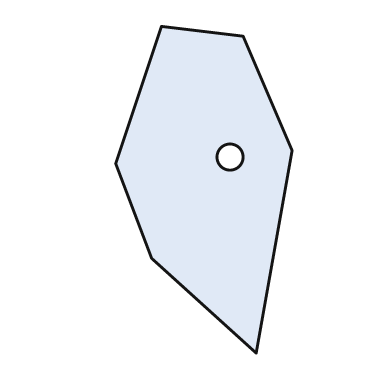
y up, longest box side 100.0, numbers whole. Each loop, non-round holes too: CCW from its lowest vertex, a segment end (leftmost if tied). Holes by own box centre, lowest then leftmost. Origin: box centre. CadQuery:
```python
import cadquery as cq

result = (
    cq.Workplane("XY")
    .moveTo(16.0, -50.0)
    .lineTo(27.0, 12.0)
    .lineTo(12.0, 47.0)
    .lineTo(-13.0, 50.0)
    .lineTo(-27.0, 8.0)
    .lineTo(-16.0, -21.0)
    .close()
    .moveTo(8.0, 10.0)
    .circle(4.0)
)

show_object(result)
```